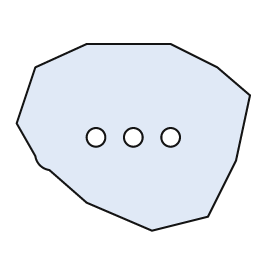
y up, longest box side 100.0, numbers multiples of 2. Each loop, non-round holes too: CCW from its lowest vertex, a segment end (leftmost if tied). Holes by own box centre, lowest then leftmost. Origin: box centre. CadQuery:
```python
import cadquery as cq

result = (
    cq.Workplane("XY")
    .moveTo(8.0, -40.0)
    .lineTo(32.0, -34.0)
    .lineTo(44.0, -10.0)
    .lineTo(50.0, 18.0)
    .lineTo(36.0, 30.0)
    .lineTo(16.0, 40.0)
    .lineTo(-20.0, 40.0)
    .lineTo(-42.0, 30.0)
    .lineTo(-50.0, 6.0)
    .lineTo(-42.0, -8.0)
    .threePointArc((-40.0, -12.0), (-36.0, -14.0))
    .lineTo(-20.0, -28.0)
    .close()
    .moveTo(-16.0, 0.0)
    .circle(4.0)
    .moveTo(0.0, 0.0)
    .circle(4.0)
    .moveTo(16.0, 0.0)
    .circle(4.0)
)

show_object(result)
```